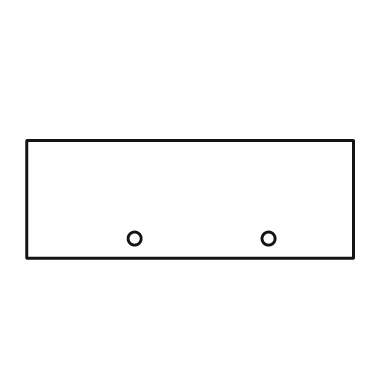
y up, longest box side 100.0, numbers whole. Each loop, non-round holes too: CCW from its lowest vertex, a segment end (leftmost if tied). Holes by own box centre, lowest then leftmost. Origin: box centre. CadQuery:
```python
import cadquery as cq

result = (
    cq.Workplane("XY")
    .moveTo(-50.0, -18.0)
    .lineTo(50.0, -18.0)
    .lineTo(50.0, 18.0)
    .lineTo(-50.0, 18.0)
    .close()
    .moveTo(-17.0, -12.0)
    .circle(2.0)
    .moveTo(24.0, -12.0)
    .circle(2.0)
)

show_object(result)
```